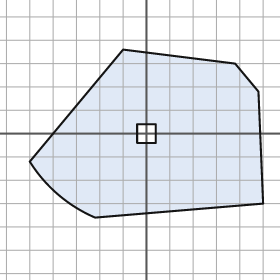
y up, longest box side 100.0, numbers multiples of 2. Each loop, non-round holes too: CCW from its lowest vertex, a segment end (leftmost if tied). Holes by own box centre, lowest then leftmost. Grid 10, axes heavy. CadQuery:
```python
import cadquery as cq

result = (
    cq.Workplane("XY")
    .moveTo(-22.0, -36.0)
    .lineTo(50.0, -30.0)
    .lineTo(48.0, 18.0)
    .lineTo(38.0, 30.0)
    .lineTo(-10.0, 36.0)
    .lineTo(-50.0, -12.0)
    .threePointArc((-38.0, -26.0), (-22.0, -36.0))
    .close()
    .moveTo(-4.0, -4.0)
    .lineTo(4.0, -4.0)
    .lineTo(4.0, 4.0)
    .lineTo(-4.0, 4.0)
    .close()
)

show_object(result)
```